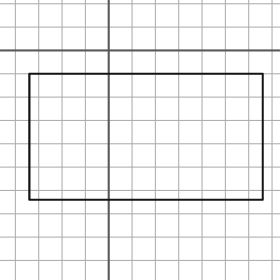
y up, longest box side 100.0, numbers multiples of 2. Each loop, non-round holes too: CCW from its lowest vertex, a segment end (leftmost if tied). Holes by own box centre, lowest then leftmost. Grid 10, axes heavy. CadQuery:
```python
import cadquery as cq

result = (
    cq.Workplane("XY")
    .moveTo(-34.0, -64.0)
    .lineTo(66.0, -64.0)
    .lineTo(66.0, -10.0)
    .lineTo(-34.0, -10.0)
    .close()
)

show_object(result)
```